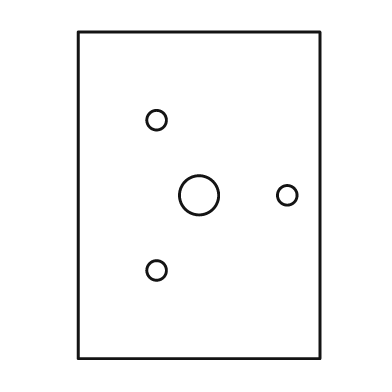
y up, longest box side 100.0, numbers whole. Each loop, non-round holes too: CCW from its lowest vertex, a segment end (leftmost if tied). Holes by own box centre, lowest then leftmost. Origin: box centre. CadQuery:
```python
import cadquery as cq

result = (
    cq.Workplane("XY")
    .moveTo(-37.0, -50.0)
    .lineTo(37.0, -50.0)
    .lineTo(37.0, 50.0)
    .lineTo(-37.0, 50.0)
    .close()
    .moveTo(-13.0, -23.0)
    .circle(3.0)
    .moveTo(0.0, 0.0)
    .circle(6.0)
    .moveTo(27.0, 0.0)
    .circle(3.0)
    .moveTo(-13.0, 23.0)
    .circle(3.0)
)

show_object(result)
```